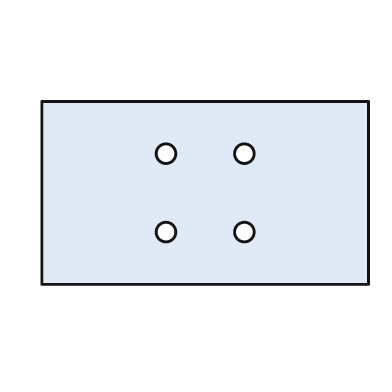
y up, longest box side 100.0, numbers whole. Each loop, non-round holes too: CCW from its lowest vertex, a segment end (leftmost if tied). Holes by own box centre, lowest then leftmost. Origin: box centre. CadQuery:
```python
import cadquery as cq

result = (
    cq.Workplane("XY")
    .moveTo(-50.0, -28.0)
    .lineTo(50.0, -28.0)
    .lineTo(50.0, 28.0)
    .lineTo(-50.0, 28.0)
    .close()
    .moveTo(-12.0, -12.0)
    .circle(3.0)
    .moveTo(12.0, -12.0)
    .circle(3.0)
    .moveTo(-12.0, 12.0)
    .circle(3.0)
    .moveTo(12.0, 12.0)
    .circle(3.0)
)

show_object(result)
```